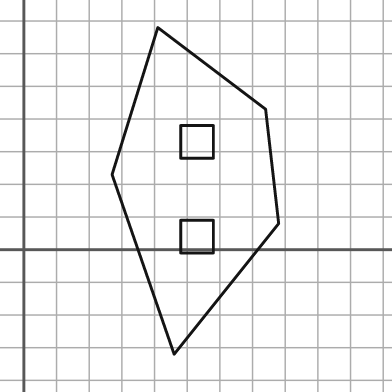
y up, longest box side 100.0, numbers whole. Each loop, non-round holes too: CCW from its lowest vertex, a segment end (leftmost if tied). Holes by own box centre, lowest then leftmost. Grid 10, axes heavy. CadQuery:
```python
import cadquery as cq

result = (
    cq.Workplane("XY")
    .moveTo(46.0, -32.0)
    .lineTo(78.0, 8.0)
    .lineTo(74.0, 43.0)
    .lineTo(41.0, 68.0)
    .lineTo(27.0, 23.0)
    .close()
    .moveTo(48.0, -1.0)
    .lineTo(58.0, -1.0)
    .lineTo(58.0, 9.0)
    .lineTo(48.0, 9.0)
    .close()
    .moveTo(48.0, 28.0)
    .lineTo(58.0, 28.0)
    .lineTo(58.0, 38.0)
    .lineTo(48.0, 38.0)
    .close()
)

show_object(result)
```